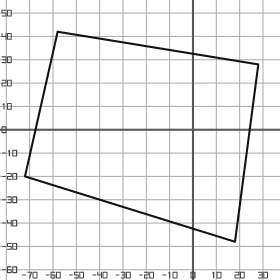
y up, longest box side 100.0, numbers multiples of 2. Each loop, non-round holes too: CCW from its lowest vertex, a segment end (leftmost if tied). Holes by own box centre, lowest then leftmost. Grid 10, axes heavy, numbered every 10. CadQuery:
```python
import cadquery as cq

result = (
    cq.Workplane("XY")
    .moveTo(18.0, -48.0)
    .lineTo(28.0, 28.0)
    .lineTo(-58.0, 42.0)
    .lineTo(-72.0, -20.0)
    .close()
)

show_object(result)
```